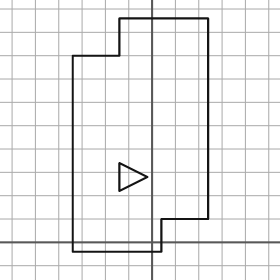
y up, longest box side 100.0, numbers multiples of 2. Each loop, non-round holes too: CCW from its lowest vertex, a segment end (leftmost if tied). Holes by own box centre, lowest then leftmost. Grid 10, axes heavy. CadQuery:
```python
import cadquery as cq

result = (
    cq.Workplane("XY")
    .moveTo(-34.0, -4.0)
    .lineTo(4.0, -4.0)
    .lineTo(4.0, 10.0)
    .lineTo(24.0, 10.0)
    .lineTo(24.0, 96.0)
    .lineTo(-14.0, 96.0)
    .lineTo(-14.0, 80.0)
    .lineTo(-34.0, 80.0)
    .close()
    .moveTo(-14.0, 22.0)
    .lineTo(-2.0, 28.0)
    .lineTo(-14.0, 34.0)
    .close()
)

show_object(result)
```